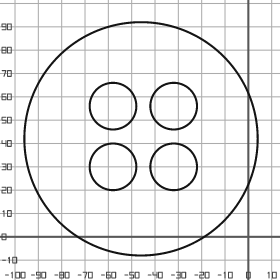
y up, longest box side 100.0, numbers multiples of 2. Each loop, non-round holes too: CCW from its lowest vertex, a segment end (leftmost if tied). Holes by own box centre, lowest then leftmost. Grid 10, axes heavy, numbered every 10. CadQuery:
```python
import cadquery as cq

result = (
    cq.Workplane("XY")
    .moveTo(-46.0, 42.0)
    .circle(50.0)
    .moveTo(-58.0, 30.0)
    .circle(10.0)
    .moveTo(-32.0, 30.0)
    .circle(10.0)
    .moveTo(-58.0, 56.0)
    .circle(10.0)
    .moveTo(-32.0, 56.0)
    .circle(10.0)
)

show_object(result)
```